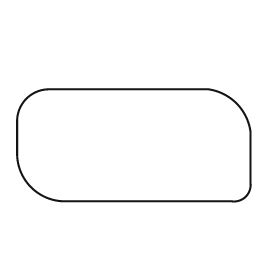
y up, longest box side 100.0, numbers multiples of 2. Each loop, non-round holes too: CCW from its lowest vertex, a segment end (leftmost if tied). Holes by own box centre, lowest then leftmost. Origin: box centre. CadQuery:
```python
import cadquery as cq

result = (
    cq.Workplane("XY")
    .moveTo(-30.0, -24.0)
    .lineTo(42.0, -24.0)
    .threePointArc((48.0, -22.0), (50.0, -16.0))
    .lineTo(50.0, 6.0)
    .threePointArc((44.0, 18.0), (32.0, 24.0))
    .lineTo(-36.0, 24.0)
    .threePointArc((-46.0, 20.0), (-50.0, 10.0))
    .lineTo(-50.0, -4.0)
    .threePointArc((-44.0, -18.0), (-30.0, -24.0))
    .close()
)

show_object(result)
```